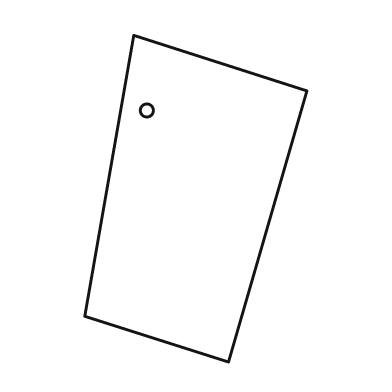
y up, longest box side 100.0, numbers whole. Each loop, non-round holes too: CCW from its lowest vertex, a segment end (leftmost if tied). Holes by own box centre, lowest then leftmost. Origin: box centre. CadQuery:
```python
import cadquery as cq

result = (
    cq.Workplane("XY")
    .moveTo(10.0, -50.0)
    .lineTo(34.0, 33.0)
    .lineTo(-19.0, 50.0)
    .lineTo(-34.0, -36.0)
    .close()
    .moveTo(-15.0, 27.0)
    .circle(2.0)
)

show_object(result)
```